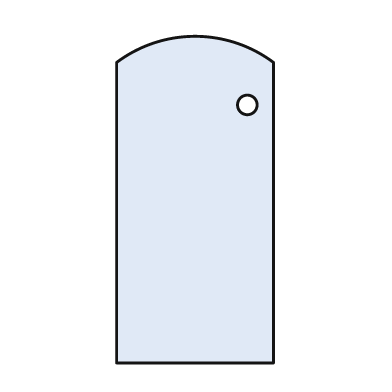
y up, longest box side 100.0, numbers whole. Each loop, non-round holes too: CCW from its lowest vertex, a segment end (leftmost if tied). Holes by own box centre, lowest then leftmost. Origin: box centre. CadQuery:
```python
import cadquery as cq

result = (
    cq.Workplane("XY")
    .moveTo(-24.0, -50.0)
    .lineTo(24.0, -50.0)
    .lineTo(24.0, 42.0)
    .threePointArc((0.0, 50.0), (-24.0, 42.0))
    .close()
    .moveTo(16.0, 29.0)
    .circle(3.0)
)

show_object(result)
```